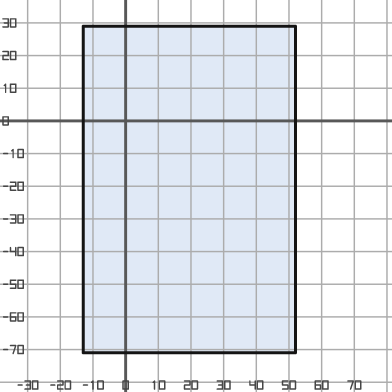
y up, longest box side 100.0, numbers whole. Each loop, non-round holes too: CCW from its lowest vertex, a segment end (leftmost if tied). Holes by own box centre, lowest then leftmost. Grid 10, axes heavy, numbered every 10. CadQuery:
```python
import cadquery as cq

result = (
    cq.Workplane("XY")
    .moveTo(-13.0, -71.0)
    .lineTo(52.0, -71.0)
    .lineTo(52.0, 29.0)
    .lineTo(-13.0, 29.0)
    .close()
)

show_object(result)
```